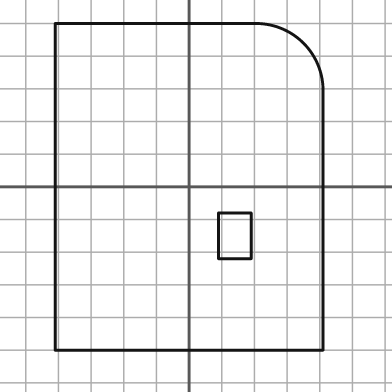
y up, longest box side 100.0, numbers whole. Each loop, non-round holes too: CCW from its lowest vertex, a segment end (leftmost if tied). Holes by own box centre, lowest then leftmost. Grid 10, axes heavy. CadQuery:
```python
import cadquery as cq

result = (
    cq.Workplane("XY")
    .moveTo(-41.0, -50.0)
    .lineTo(41.0, -50.0)
    .lineTo(41.0, 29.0)
    .threePointArc((35.0, 44.0), (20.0, 50.0))
    .lineTo(-41.0, 50.0)
    .close()
    .moveTo(9.0, -22.0)
    .lineTo(19.0, -22.0)
    .lineTo(19.0, -8.0)
    .lineTo(9.0, -8.0)
    .close()
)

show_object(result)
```